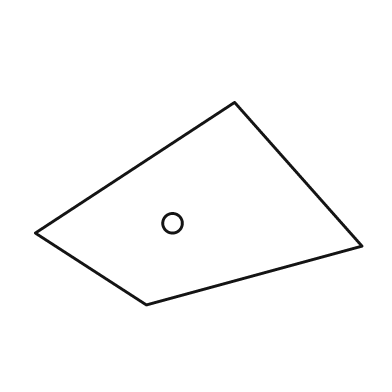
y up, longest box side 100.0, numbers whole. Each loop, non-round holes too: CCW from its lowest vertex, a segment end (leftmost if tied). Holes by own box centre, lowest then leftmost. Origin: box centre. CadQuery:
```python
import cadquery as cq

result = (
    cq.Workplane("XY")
    .moveTo(-16.0, -31.0)
    .lineTo(50.0, -13.0)
    .lineTo(11.0, 31.0)
    .lineTo(-50.0, -9.0)
    .close()
    .moveTo(-8.0, -6.0)
    .circle(3.0)
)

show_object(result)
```